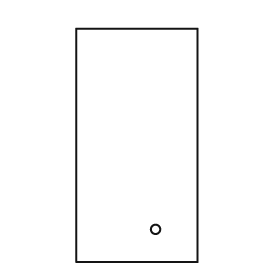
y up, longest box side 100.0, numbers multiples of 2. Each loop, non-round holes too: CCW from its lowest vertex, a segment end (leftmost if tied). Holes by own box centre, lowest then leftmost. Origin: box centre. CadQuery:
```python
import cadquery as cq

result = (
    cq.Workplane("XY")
    .moveTo(-26.0, -50.0)
    .lineTo(26.0, -50.0)
    .lineTo(26.0, 50.0)
    .lineTo(-26.0, 50.0)
    .close()
    .moveTo(8.0, -36.0)
    .circle(2.0)
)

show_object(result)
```